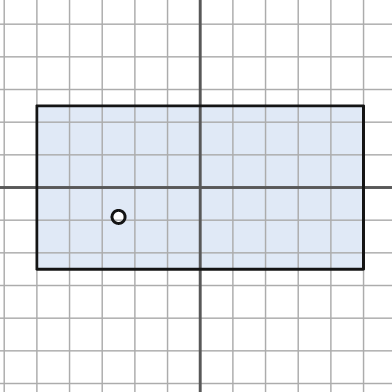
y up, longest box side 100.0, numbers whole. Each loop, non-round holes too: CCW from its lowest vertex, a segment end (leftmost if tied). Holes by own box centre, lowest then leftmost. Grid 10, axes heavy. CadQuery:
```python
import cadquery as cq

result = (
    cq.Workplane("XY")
    .moveTo(-50.0, -25.0)
    .lineTo(50.0, -25.0)
    .lineTo(50.0, 25.0)
    .lineTo(-50.0, 25.0)
    .close()
    .moveTo(-25.0, -9.0)
    .circle(2.0)
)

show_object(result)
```